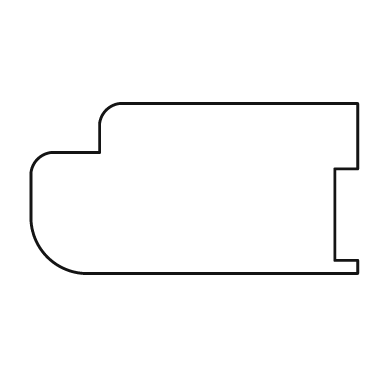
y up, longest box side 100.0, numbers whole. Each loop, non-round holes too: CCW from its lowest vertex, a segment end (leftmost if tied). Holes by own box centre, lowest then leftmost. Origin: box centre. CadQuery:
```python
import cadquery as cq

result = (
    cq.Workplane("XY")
    .moveTo(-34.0, -26.0)
    .lineTo(50.0, -26.0)
    .lineTo(50.0, -22.0)
    .lineTo(43.0, -22.0)
    .lineTo(43.0, 6.0)
    .lineTo(50.0, 6.0)
    .lineTo(50.0, 26.0)
    .lineTo(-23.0, 26.0)
    .threePointArc((-27.0, 24.0), (-29.0, 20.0))
    .lineTo(-29.0, 11.0)
    .lineTo(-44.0, 11.0)
    .threePointArc((-48.0, 9.0), (-50.0, 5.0))
    .lineTo(-50.0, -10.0)
    .threePointArc((-45.0, -21.0), (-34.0, -26.0))
    .close()
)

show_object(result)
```